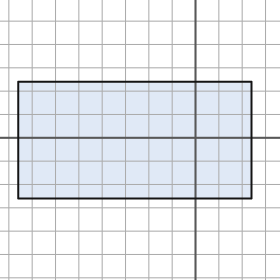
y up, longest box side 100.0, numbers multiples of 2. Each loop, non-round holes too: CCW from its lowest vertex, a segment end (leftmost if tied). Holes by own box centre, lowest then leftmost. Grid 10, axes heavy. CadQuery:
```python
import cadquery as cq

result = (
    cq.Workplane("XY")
    .moveTo(-76.0, -26.0)
    .lineTo(24.0, -26.0)
    .lineTo(24.0, 24.0)
    .lineTo(-76.0, 24.0)
    .close()
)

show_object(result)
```